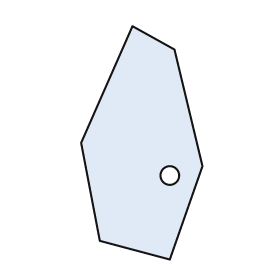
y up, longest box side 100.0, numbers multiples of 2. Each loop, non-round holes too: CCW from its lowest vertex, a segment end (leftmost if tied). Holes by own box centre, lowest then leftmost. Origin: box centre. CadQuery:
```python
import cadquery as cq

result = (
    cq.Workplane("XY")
    .moveTo(12.0, -50.0)
    .lineTo(26.0, -10.0)
    .lineTo(14.0, 40.0)
    .lineTo(-4.0, 50.0)
    .lineTo(-26.0, 0.0)
    .lineTo(-18.0, -42.0)
    .close()
    .moveTo(12.0, -14.0)
    .circle(4.0)
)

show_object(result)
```